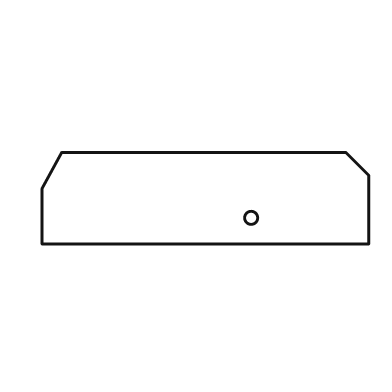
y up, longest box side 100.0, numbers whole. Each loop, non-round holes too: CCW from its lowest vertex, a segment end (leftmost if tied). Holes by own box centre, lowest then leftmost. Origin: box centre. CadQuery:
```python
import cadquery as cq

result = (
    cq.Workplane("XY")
    .moveTo(-50.0, -14.0)
    .lineTo(50.0, -14.0)
    .lineTo(50.0, 7.0)
    .lineTo(43.0, 14.0)
    .lineTo(-44.0, 14.0)
    .lineTo(-50.0, 3.0)
    .close()
    .moveTo(14.0, -6.0)
    .circle(2.0)
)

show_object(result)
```